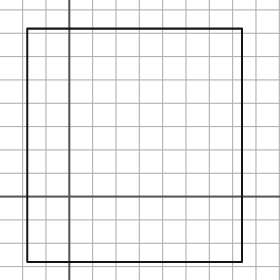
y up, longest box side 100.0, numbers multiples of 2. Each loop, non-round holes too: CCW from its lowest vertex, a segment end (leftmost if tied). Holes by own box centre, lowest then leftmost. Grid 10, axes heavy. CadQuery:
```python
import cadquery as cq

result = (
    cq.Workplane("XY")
    .moveTo(-18.0, -28.0)
    .lineTo(74.0, -28.0)
    .lineTo(74.0, 72.0)
    .lineTo(-18.0, 72.0)
    .close()
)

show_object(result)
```